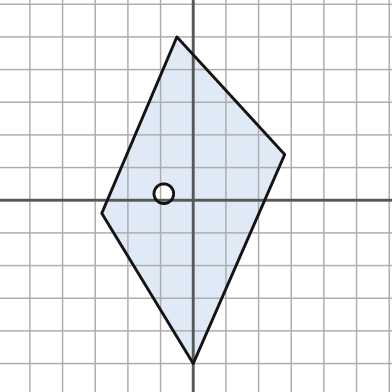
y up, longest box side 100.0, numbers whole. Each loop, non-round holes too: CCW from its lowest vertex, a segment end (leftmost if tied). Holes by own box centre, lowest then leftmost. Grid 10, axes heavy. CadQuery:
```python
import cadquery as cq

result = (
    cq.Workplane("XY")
    .moveTo(0.0, -50.0)
    .lineTo(28.0, 14.0)
    .lineTo(-5.0, 50.0)
    .lineTo(-28.0, -4.0)
    .close()
    .moveTo(-9.0, 2.0)
    .circle(3.0)
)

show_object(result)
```